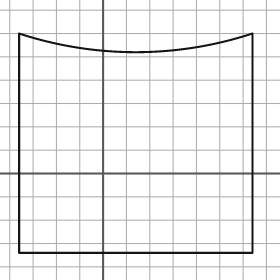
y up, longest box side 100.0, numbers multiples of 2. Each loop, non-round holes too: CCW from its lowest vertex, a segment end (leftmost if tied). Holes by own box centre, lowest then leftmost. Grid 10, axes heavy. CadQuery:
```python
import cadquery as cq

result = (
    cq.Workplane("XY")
    .moveTo(-36.0, -34.0)
    .lineTo(64.0, -34.0)
    .lineTo(64.0, 60.0)
    .threePointArc((14.0, 52.0), (-36.0, 60.0))
    .close()
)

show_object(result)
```